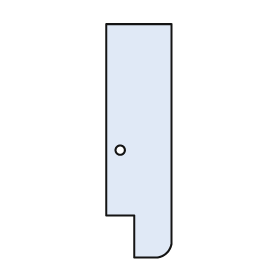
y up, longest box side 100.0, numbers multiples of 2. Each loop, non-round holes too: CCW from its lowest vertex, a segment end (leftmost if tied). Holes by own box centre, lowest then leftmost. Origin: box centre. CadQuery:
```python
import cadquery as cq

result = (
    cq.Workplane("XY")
    .moveTo(-2.0, -50.0)
    .lineTo(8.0, -50.0)
    .threePointArc((12.0, -48.0), (14.0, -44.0))
    .lineTo(14.0, 50.0)
    .lineTo(-14.0, 50.0)
    .lineTo(-14.0, -32.0)
    .lineTo(-2.0, -32.0)
    .close()
    .moveTo(-8.0, -4.0)
    .circle(2.0)
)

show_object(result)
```